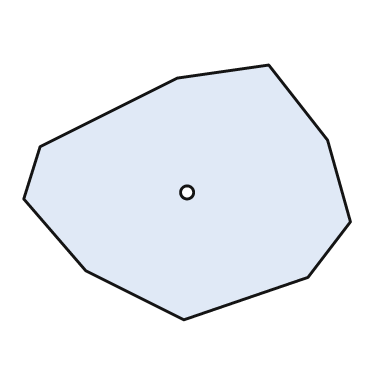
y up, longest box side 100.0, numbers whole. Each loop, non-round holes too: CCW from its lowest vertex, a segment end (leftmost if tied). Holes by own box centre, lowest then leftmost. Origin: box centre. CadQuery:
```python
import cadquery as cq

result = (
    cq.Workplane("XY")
    .moveTo(-1.0, -39.0)
    .lineTo(37.0, -26.0)
    .lineTo(50.0, -9.0)
    .lineTo(43.0, 16.0)
    .lineTo(25.0, 39.0)
    .lineTo(-3.0, 35.0)
    .lineTo(-45.0, 14.0)
    .lineTo(-50.0, -2.0)
    .lineTo(-31.0, -24.0)
    .close()
    .moveTo(0.0, 0.0)
    .circle(2.0)
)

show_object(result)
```